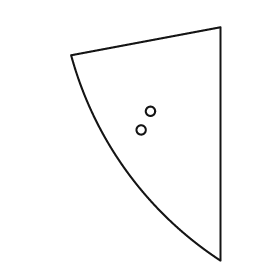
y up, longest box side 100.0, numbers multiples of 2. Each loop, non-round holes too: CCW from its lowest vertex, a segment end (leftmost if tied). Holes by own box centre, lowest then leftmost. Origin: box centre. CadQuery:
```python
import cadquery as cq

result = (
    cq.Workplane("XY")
    .moveTo(32.0, -50.0)
    .lineTo(32.0, 50.0)
    .lineTo(-32.0, 38.0)
    .threePointArc((-8.0, -12.0), (32.0, -50.0))
    .close()
    .moveTo(-2.0, 6.0)
    .circle(2.0)
    .moveTo(2.0, 14.0)
    .circle(2.0)
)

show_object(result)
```